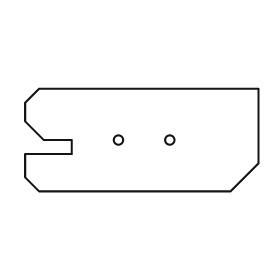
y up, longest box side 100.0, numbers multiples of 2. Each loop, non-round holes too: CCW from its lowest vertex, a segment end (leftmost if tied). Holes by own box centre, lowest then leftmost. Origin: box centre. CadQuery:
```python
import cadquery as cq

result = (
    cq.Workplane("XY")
    .moveTo(-44.0, -22.0)
    .lineTo(38.0, -22.0)
    .lineTo(50.0, -10.0)
    .lineTo(50.0, 22.0)
    .lineTo(-44.0, 22.0)
    .lineTo(-50.0, 16.0)
    .lineTo(-50.0, 8.0)
    .lineTo(-42.0, 0.0)
    .lineTo(-30.0, 0.0)
    .lineTo(-30.0, -6.0)
    .lineTo(-50.0, -6.0)
    .lineTo(-50.0, -16.0)
    .close()
    .moveTo(-10.0, 0.0)
    .circle(2.0)
    .moveTo(12.0, 0.0)
    .circle(2.0)
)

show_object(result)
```